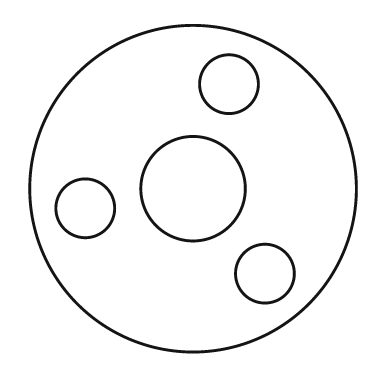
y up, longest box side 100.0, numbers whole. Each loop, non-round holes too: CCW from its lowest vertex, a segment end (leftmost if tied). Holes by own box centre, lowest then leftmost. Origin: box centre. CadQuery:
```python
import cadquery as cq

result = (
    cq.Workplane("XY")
    .moveTo(0.0, 0.0)
    .circle(50.0)
    .moveTo(22.0, -26.0)
    .circle(9.0)
    .moveTo(-33.0, -6.0)
    .circle(9.0)
    .moveTo(0.0, 0.0)
    .circle(16.0)
    .moveTo(11.0, 32.0)
    .circle(9.0)
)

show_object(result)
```